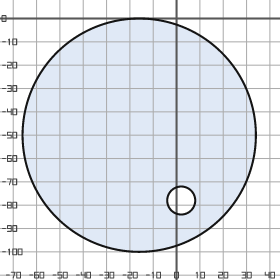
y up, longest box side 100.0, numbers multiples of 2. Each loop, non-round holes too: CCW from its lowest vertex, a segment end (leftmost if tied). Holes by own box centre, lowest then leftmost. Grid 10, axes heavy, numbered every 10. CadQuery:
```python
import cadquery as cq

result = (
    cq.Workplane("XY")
    .moveTo(-16.0, -50.0)
    .circle(50.0)
    .moveTo(2.0, -78.0)
    .circle(6.0)
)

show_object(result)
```